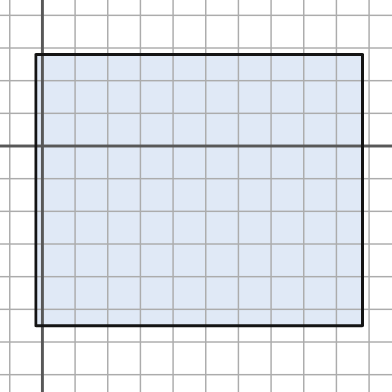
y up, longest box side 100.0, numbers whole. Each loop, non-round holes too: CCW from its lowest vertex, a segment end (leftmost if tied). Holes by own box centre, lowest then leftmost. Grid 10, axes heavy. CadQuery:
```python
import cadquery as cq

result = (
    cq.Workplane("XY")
    .moveTo(-2.0, -55.0)
    .lineTo(98.0, -55.0)
    .lineTo(98.0, 28.0)
    .lineTo(-2.0, 28.0)
    .close()
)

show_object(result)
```